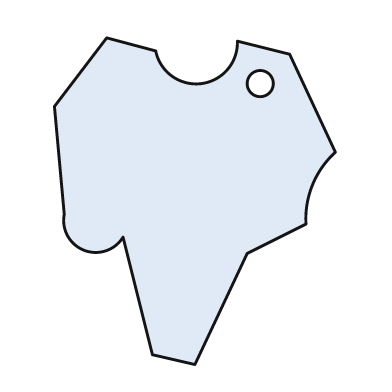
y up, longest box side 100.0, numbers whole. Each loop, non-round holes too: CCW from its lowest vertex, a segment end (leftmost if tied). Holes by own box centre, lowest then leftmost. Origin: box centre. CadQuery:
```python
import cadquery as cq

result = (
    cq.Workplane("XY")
    .moveTo(0.0, -50.0)
    .lineTo(16.0, -16.0)
    .lineTo(34.0, -7.0)
    .threePointArc((36.0, 5.0), (43.0, 15.0))
    .lineTo(29.0, 45.0)
    .lineTo(13.0, 49.0)
    .threePointArc((2.0, 36.0), (-12.0, 46.0))
    .lineTo(-27.0, 50.0)
    .lineTo(-43.0, 29.0)
    .lineTo(-40.0, -4.0)
    .threePointArc((-34.0, -15.0), (-22.0, -11.0))
    .lineTo(-13.0, -47.0)
    .close()
    .moveTo(20.0, 36.0)
    .circle(4.0)
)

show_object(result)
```